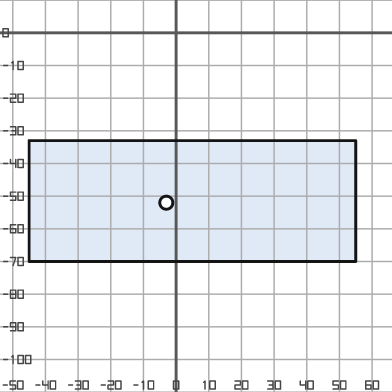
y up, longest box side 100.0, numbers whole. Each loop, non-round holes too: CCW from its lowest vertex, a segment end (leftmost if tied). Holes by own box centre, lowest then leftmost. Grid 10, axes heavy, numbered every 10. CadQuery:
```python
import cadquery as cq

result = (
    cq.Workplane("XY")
    .moveTo(-45.0, -70.0)
    .lineTo(55.0, -70.0)
    .lineTo(55.0, -33.0)
    .lineTo(-45.0, -33.0)
    .close()
    .moveTo(-3.0, -52.0)
    .circle(2.0)
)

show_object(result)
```